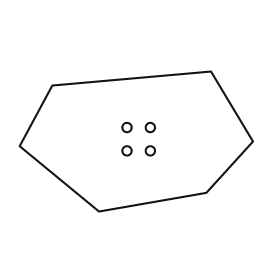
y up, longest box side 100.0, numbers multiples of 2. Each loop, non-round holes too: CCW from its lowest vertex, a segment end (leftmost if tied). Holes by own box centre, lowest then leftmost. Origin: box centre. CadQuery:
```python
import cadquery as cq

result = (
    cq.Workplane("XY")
    .moveTo(-16.0, -30.0)
    .lineTo(30.0, -22.0)
    .lineTo(50.0, 0.0)
    .lineTo(32.0, 30.0)
    .lineTo(-36.0, 24.0)
    .lineTo(-50.0, -2.0)
    .close()
    .moveTo(-4.0, -4.0)
    .circle(2.0)
    .moveTo(6.0, -4.0)
    .circle(2.0)
    .moveTo(-4.0, 6.0)
    .circle(2.0)
    .moveTo(6.0, 6.0)
    .circle(2.0)
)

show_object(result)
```